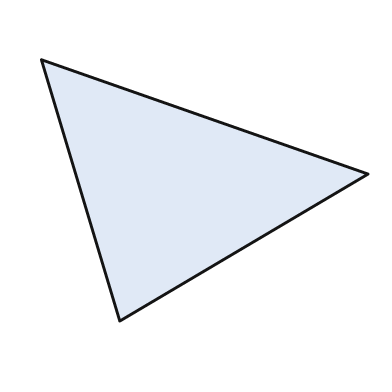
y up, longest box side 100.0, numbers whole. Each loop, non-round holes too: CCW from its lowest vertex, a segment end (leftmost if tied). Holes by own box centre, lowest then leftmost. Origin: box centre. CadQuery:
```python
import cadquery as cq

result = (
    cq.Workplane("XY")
    .moveTo(-26.0, -40.0)
    .lineTo(50.0, 5.0)
    .lineTo(-50.0, 40.0)
    .close()
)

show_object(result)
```